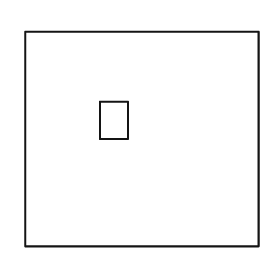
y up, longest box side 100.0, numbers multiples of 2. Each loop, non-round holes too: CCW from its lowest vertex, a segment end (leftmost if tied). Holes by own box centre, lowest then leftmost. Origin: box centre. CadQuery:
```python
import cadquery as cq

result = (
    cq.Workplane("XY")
    .moveTo(-50.0, -46.0)
    .lineTo(50.0, -46.0)
    .lineTo(50.0, 46.0)
    .lineTo(-50.0, 46.0)
    .close()
    .moveTo(-18.0, 0.0)
    .lineTo(-6.0, 0.0)
    .lineTo(-6.0, 16.0)
    .lineTo(-18.0, 16.0)
    .close()
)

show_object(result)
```